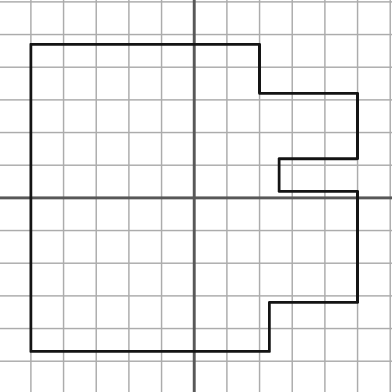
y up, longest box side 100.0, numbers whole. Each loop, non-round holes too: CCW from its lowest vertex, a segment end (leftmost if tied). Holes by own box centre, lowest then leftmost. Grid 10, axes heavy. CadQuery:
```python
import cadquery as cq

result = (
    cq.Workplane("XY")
    .moveTo(-50.0, -47.0)
    .lineTo(23.0, -47.0)
    .lineTo(23.0, -32.0)
    .lineTo(50.0, -32.0)
    .lineTo(50.0, 2.0)
    .lineTo(26.0, 2.0)
    .lineTo(26.0, 12.0)
    .lineTo(50.0, 12.0)
    .lineTo(50.0, 32.0)
    .lineTo(20.0, 32.0)
    .lineTo(20.0, 47.0)
    .lineTo(-50.0, 47.0)
    .close()
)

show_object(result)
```